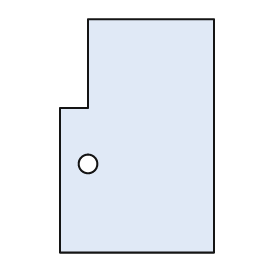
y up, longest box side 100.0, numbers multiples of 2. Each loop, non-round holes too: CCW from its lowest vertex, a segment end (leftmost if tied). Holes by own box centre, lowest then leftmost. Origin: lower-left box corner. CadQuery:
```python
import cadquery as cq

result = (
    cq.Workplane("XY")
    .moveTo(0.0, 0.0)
    .lineTo(66.0, 0.0)
    .lineTo(66.0, 100.0)
    .lineTo(12.0, 100.0)
    .lineTo(12.0, 62.0)
    .lineTo(0.0, 62.0)
    .close()
    .moveTo(12.0, 38.0)
    .circle(4.0)
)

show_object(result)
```